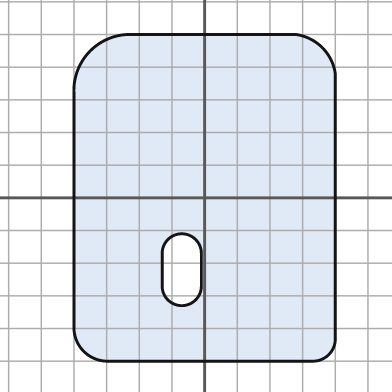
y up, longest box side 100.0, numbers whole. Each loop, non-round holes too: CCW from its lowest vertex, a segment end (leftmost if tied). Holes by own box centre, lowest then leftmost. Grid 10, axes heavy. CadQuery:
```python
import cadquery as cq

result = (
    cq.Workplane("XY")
    .moveTo(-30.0, -50.0)
    .lineTo(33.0, -50.0)
    .threePointArc((38.0, -48.0), (40.0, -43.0))
    .lineTo(40.0, 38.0)
    .threePointArc((36.0, 46.0), (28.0, 50.0))
    .lineTo(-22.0, 50.0)
    .threePointArc((-35.0, 45.0), (-40.0, 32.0))
    .lineTo(-40.0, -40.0)
    .threePointArc((-37.0, -47.0), (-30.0, -50.0))
    .close()
    .moveTo(-13.0, -27.0)
    .threePointArc((-7.0, -33.0), (-1.0, -27.0))
    .lineTo(-1.0, -17.0)
    .threePointArc((-7.0, -11.0), (-13.0, -17.0))
    .close()
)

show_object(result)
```